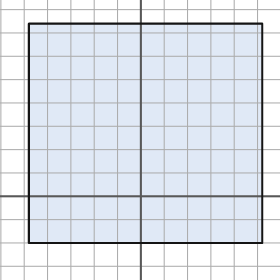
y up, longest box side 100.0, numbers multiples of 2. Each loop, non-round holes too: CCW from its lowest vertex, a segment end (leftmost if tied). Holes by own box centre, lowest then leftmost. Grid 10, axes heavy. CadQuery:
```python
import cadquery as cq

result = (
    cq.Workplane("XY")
    .moveTo(-48.0, -20.0)
    .lineTo(52.0, -20.0)
    .lineTo(52.0, 74.0)
    .lineTo(-48.0, 74.0)
    .close()
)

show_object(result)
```